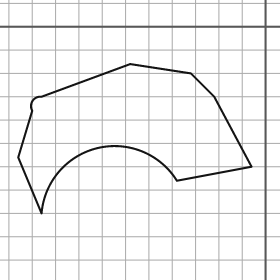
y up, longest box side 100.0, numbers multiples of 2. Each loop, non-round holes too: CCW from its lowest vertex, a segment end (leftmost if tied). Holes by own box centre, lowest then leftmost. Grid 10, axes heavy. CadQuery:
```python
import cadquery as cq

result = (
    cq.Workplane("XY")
    .moveTo(-96.0, -80.0)
    .threePointArc((-72.0, -52.0), (-38.0, -66.0))
    .lineTo(-6.0, -60.0)
    .lineTo(-22.0, -30.0)
    .lineTo(-32.0, -20.0)
    .lineTo(-58.0, -16.0)
    .lineTo(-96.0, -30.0)
    .threePointArc((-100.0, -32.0), (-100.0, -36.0))
    .lineTo(-106.0, -56.0)
    .close()
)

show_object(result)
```